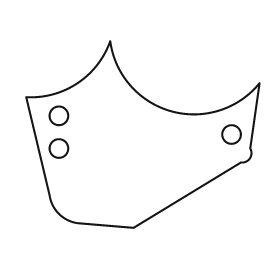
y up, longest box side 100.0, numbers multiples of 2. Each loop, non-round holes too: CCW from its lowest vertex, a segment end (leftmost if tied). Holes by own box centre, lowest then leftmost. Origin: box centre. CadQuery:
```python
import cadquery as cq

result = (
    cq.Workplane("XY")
    .moveTo(-4.0, -40.0)
    .lineTo(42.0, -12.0)
    .threePointArc((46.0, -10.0), (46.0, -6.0))
    .lineTo(50.0, 22.0)
    .threePointArc((12.0, 10.0), (-14.0, 40.0))
    .threePointArc((-28.0, 22.0), (-50.0, 16.0))
    .lineTo(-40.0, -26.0)
    .threePointArc((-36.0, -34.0), (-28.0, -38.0))
    .close()
    .moveTo(-36.0, -6.0)
    .circle(4.0)
    .moveTo(38.0, 0.0)
    .circle(4.0)
    .moveTo(-36.0, 8.0)
    .circle(4.0)
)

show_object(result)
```